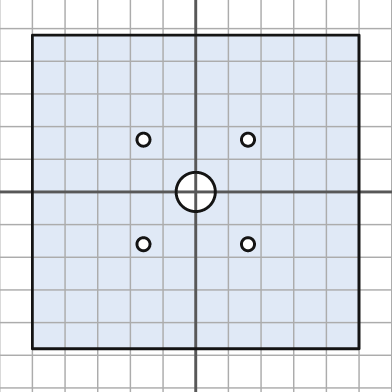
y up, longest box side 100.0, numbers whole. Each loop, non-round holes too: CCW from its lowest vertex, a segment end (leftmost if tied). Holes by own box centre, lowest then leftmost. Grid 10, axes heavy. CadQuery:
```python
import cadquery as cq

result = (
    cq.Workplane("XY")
    .moveTo(-50.0, -48.0)
    .lineTo(50.0, -48.0)
    .lineTo(50.0, 48.0)
    .lineTo(-50.0, 48.0)
    .close()
    .moveTo(-16.0, -16.0)
    .circle(2.0)
    .moveTo(16.0, -16.0)
    .circle(2.0)
    .moveTo(0.0, 0.0)
    .circle(6.0)
    .moveTo(-16.0, 16.0)
    .circle(2.0)
    .moveTo(16.0, 16.0)
    .circle(2.0)
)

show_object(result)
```